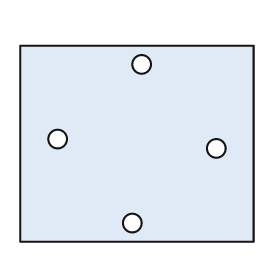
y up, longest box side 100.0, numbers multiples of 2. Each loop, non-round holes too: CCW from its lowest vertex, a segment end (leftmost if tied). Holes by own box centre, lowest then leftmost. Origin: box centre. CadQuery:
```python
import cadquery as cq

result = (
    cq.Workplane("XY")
    .moveTo(-50.0, -42.0)
    .lineTo(50.0, -42.0)
    .lineTo(50.0, 42.0)
    .lineTo(-50.0, 42.0)
    .close()
    .moveTo(-2.0, -34.0)
    .circle(4.0)
    .moveTo(34.0, -2.0)
    .circle(4.0)
    .moveTo(-34.0, 2.0)
    .circle(4.0)
    .moveTo(2.0, 34.0)
    .circle(4.0)
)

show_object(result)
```